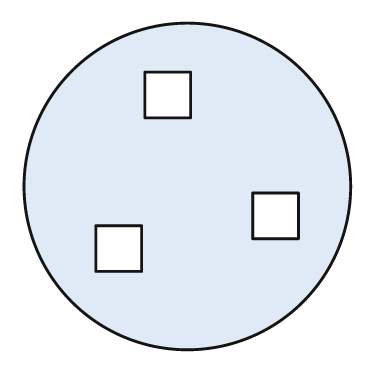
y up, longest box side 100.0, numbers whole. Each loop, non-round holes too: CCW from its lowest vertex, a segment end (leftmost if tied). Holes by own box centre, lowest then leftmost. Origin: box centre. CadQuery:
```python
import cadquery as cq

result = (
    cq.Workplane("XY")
    .moveTo(0.0, 0.0)
    .circle(50.0)
    .moveTo(-28.0, -26.0)
    .lineTo(-14.0, -26.0)
    .lineTo(-14.0, -12.0)
    .lineTo(-28.0, -12.0)
    .close()
    .moveTo(20.0, -16.0)
    .lineTo(34.0, -16.0)
    .lineTo(34.0, -2.0)
    .lineTo(20.0, -2.0)
    .close()
    .moveTo(-13.0, 21.0)
    .lineTo(1.0, 21.0)
    .lineTo(1.0, 35.0)
    .lineTo(-13.0, 35.0)
    .close()
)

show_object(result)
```